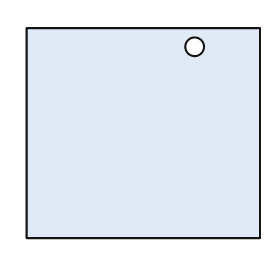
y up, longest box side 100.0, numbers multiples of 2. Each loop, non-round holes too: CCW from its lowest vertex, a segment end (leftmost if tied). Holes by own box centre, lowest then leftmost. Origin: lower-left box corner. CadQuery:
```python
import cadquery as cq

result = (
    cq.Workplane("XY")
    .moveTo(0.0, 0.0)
    .lineTo(100.0, 0.0)
    .lineTo(100.0, 90.0)
    .lineTo(0.0, 90.0)
    .close()
    .moveTo(72.0, 82.0)
    .circle(4.0)
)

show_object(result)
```